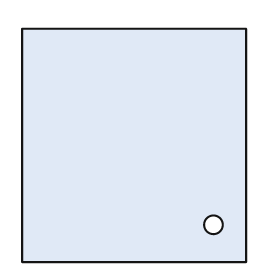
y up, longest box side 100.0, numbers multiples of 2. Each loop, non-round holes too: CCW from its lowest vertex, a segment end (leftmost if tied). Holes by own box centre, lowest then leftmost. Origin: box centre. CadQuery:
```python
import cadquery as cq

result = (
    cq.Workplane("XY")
    .moveTo(-48.0, -50.0)
    .lineTo(48.0, -50.0)
    .lineTo(48.0, 50.0)
    .lineTo(-48.0, 50.0)
    .close()
    .moveTo(34.0, -34.0)
    .circle(4.0)
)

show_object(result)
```